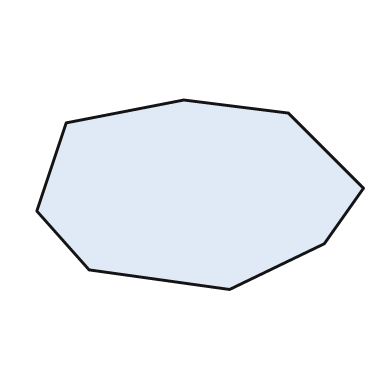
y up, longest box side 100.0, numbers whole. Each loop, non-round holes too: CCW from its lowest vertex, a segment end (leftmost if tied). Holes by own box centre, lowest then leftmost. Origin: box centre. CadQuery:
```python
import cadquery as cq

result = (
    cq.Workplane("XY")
    .moveTo(9.0, -29.0)
    .lineTo(38.0, -15.0)
    .lineTo(50.0, 2.0)
    .lineTo(27.0, 25.0)
    .lineTo(-5.0, 29.0)
    .lineTo(-41.0, 22.0)
    .lineTo(-50.0, -5.0)
    .lineTo(-34.0, -23.0)
    .close()
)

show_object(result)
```